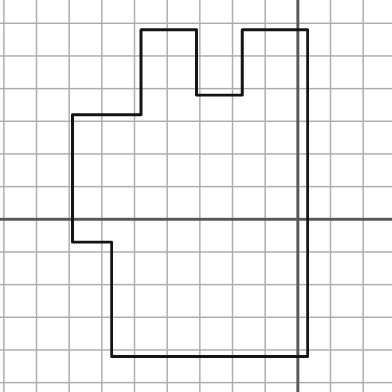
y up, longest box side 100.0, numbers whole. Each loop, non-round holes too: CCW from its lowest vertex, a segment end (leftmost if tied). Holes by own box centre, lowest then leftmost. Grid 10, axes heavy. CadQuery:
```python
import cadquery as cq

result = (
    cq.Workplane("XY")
    .moveTo(-57.0, -42.0)
    .lineTo(3.0, -42.0)
    .lineTo(3.0, 58.0)
    .lineTo(-17.0, 58.0)
    .lineTo(-17.0, 38.0)
    .lineTo(-31.0, 38.0)
    .lineTo(-31.0, 58.0)
    .lineTo(-48.0, 58.0)
    .lineTo(-48.0, 32.0)
    .lineTo(-69.0, 32.0)
    .lineTo(-69.0, -7.0)
    .lineTo(-57.0, -7.0)
    .close()
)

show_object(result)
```